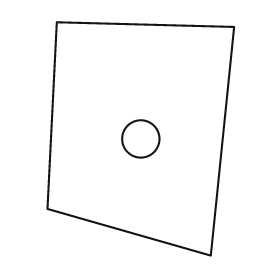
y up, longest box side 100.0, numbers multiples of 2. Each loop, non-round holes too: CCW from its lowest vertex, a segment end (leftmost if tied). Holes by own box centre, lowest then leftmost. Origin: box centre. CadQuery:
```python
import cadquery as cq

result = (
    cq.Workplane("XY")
    .moveTo(30.0, -50.0)
    .lineTo(40.0, 48.0)
    .lineTo(-36.0, 50.0)
    .lineTo(-40.0, -30.0)
    .close()
    .moveTo(0.0, 0.0)
    .circle(8.0)
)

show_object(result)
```